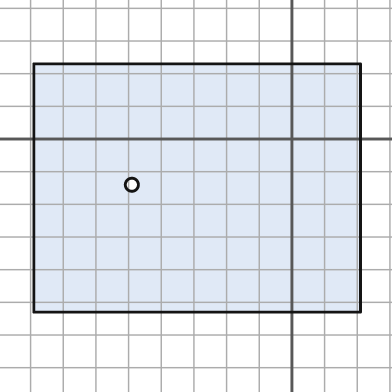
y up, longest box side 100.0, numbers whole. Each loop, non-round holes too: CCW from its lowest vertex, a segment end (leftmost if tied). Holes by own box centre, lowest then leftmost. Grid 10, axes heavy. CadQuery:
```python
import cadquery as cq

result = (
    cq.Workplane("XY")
    .moveTo(-79.0, -53.0)
    .lineTo(21.0, -53.0)
    .lineTo(21.0, 23.0)
    .lineTo(-79.0, 23.0)
    .close()
    .moveTo(-49.0, -14.0)
    .circle(2.0)
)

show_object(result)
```